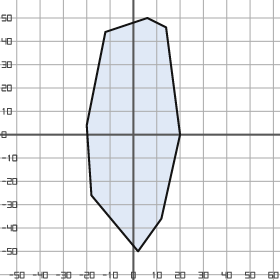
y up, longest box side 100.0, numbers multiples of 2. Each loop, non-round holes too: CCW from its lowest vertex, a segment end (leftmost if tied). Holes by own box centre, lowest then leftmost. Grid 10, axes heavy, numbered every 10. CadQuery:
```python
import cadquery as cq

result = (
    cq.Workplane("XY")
    .moveTo(2.0, -50.0)
    .lineTo(12.0, -36.0)
    .lineTo(20.0, 0.0)
    .lineTo(14.0, 46.0)
    .lineTo(6.0, 50.0)
    .lineTo(-12.0, 44.0)
    .lineTo(-20.0, 4.0)
    .lineTo(-18.0, -26.0)
    .close()
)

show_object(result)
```